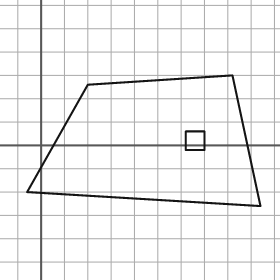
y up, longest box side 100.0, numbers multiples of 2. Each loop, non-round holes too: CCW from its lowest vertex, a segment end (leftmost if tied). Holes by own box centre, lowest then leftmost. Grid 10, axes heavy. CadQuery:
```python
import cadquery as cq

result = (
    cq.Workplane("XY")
    .moveTo(94.0, -26.0)
    .lineTo(82.0, 30.0)
    .lineTo(20.0, 26.0)
    .lineTo(-6.0, -20.0)
    .close()
    .moveTo(62.0, -2.0)
    .lineTo(70.0, -2.0)
    .lineTo(70.0, 6.0)
    .lineTo(62.0, 6.0)
    .close()
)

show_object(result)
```